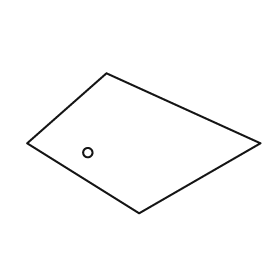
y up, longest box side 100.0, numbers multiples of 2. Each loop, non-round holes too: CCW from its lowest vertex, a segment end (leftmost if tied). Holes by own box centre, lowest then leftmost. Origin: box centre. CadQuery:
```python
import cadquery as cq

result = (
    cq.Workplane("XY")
    .moveTo(-2.0, -30.0)
    .lineTo(50.0, 0.0)
    .lineTo(-16.0, 30.0)
    .lineTo(-50.0, 0.0)
    .close()
    .moveTo(-24.0, -4.0)
    .circle(2.0)
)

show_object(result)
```